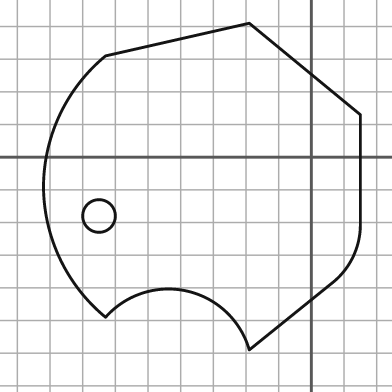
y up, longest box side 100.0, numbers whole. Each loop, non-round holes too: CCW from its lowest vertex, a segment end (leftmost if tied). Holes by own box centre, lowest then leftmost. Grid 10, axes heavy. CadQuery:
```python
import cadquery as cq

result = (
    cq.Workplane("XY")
    .moveTo(-19.0, -59.0)
    .lineTo(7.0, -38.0)
    .threePointArc((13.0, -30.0), (15.0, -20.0))
    .lineTo(15.0, 13.0)
    .lineTo(-19.0, 41.0)
    .lineTo(-63.0, 31.0)
    .threePointArc((-77.0, 13.0), (-82.0, -9.0))
    .threePointArc((-77.0, -31.0), (-63.0, -49.0))
    .threePointArc((-38.0, -41.0), (-19.0, -59.0))
    .close()
    .moveTo(-65.0, -18.0)
    .circle(5.0)
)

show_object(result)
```